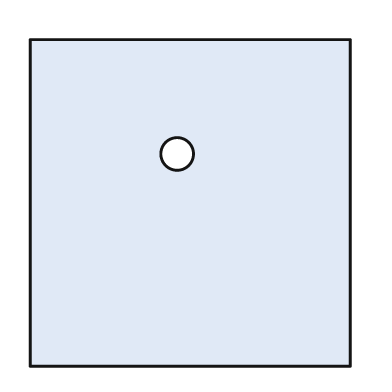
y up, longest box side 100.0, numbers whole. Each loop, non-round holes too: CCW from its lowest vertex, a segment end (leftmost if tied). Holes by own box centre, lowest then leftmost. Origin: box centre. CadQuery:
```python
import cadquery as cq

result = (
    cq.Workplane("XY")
    .moveTo(-49.0, -50.0)
    .lineTo(49.0, -50.0)
    .lineTo(49.0, 50.0)
    .lineTo(-49.0, 50.0)
    .close()
    .moveTo(-4.0, 15.0)
    .circle(5.0)
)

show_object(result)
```